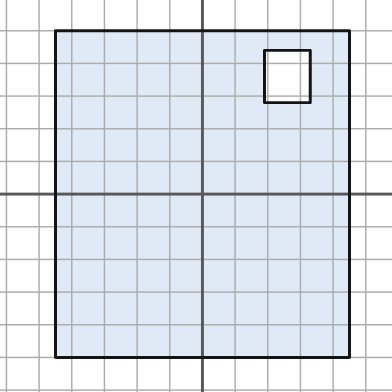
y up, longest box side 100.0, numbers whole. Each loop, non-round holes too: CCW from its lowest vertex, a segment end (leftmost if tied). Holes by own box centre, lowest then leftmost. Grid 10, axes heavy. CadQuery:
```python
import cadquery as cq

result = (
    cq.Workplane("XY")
    .moveTo(-45.0, -50.0)
    .lineTo(45.0, -50.0)
    .lineTo(45.0, 50.0)
    .lineTo(-45.0, 50.0)
    .close()
    .moveTo(19.0, 28.0)
    .lineTo(33.0, 28.0)
    .lineTo(33.0, 44.0)
    .lineTo(19.0, 44.0)
    .close()
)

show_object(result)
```